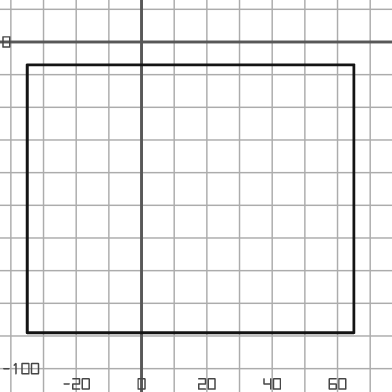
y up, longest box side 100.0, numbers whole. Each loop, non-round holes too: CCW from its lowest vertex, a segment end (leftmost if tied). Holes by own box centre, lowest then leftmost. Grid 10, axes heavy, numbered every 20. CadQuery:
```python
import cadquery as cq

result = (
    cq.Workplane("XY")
    .moveTo(-35.0, -89.0)
    .lineTo(65.0, -89.0)
    .lineTo(65.0, -7.0)
    .lineTo(-35.0, -7.0)
    .close()
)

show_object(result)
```